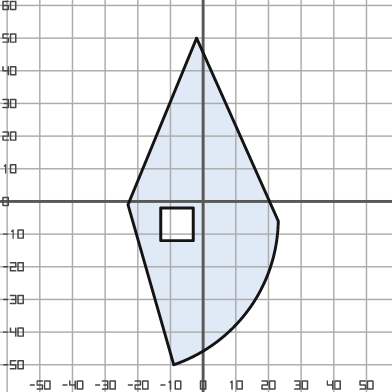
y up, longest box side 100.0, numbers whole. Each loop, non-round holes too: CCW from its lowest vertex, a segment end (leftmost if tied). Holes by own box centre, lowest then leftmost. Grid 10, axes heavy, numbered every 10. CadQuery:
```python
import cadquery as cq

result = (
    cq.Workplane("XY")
    .moveTo(-9.0, -50.0)
    .threePointArc((14.0, -33.0), (23.0, -6.0))
    .lineTo(-2.0, 50.0)
    .lineTo(-23.0, -1.0)
    .close()
    .moveTo(-13.0, -12.0)
    .lineTo(-3.0, -12.0)
    .lineTo(-3.0, -2.0)
    .lineTo(-13.0, -2.0)
    .close()
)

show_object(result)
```